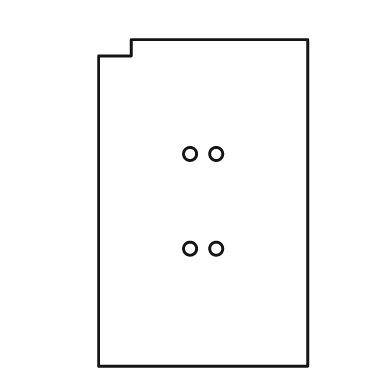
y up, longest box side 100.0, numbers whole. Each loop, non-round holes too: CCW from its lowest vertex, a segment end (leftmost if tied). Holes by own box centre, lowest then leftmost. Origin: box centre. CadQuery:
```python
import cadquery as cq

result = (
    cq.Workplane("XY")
    .moveTo(-32.0, -50.0)
    .lineTo(32.0, -50.0)
    .lineTo(32.0, 50.0)
    .lineTo(-22.0, 50.0)
    .lineTo(-22.0, 45.0)
    .lineTo(-32.0, 45.0)
    .close()
    .moveTo(-4.0, -14.0)
    .circle(2.0)
    .moveTo(4.0, -14.0)
    .circle(2.0)
    .moveTo(-4.0, 15.0)
    .circle(2.0)
    .moveTo(4.0, 15.0)
    .circle(2.0)
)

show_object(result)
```